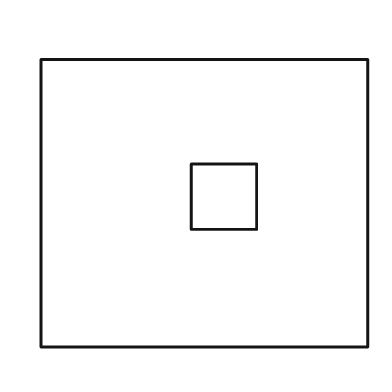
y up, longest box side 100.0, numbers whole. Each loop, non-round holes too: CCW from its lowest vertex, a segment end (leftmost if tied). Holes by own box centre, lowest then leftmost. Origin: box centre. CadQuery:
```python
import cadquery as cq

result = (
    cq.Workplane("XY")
    .moveTo(-50.0, -44.0)
    .lineTo(50.0, -44.0)
    .lineTo(50.0, 44.0)
    .lineTo(-50.0, 44.0)
    .close()
    .moveTo(-4.0, -8.0)
    .lineTo(16.0, -8.0)
    .lineTo(16.0, 12.0)
    .lineTo(-4.0, 12.0)
    .close()
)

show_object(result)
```